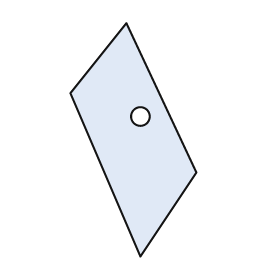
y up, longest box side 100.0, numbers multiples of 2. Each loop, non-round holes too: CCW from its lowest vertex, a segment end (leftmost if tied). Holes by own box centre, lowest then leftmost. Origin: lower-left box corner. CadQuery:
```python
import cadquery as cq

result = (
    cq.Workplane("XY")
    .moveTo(30.0, 0.0)
    .lineTo(54.0, 36.0)
    .lineTo(24.0, 100.0)
    .lineTo(0.0, 70.0)
    .close()
    .moveTo(30.0, 60.0)
    .circle(4.0)
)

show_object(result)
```